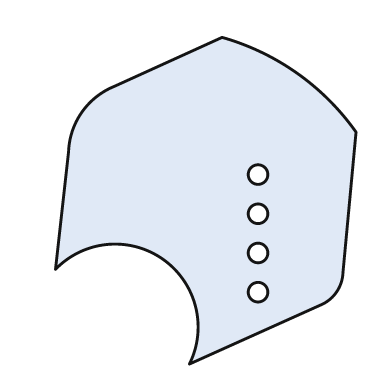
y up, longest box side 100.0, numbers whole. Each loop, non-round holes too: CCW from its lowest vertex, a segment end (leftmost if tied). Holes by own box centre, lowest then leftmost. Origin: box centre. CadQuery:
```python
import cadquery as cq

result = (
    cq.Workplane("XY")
    .moveTo(-5.0, -50.0)
    .lineTo(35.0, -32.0)
    .threePointArc((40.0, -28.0), (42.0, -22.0))
    .lineTo(46.0, 21.0)
    .threePointArc((28.0, 39.0), (5.0, 50.0))
    .lineTo(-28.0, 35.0)
    .threePointArc((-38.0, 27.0), (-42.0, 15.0))
    .lineTo(-46.0, -21.0)
    .threePointArc((-13.0, -18.0), (-5.0, -50.0))
    .close()
    .moveTo(16.0, -28.0)
    .circle(3.0)
    .moveTo(16.0, -16.0)
    .circle(3.0)
    .moveTo(16.0, -4.0)
    .circle(3.0)
    .moveTo(16.0, 8.0)
    .circle(3.0)
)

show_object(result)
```